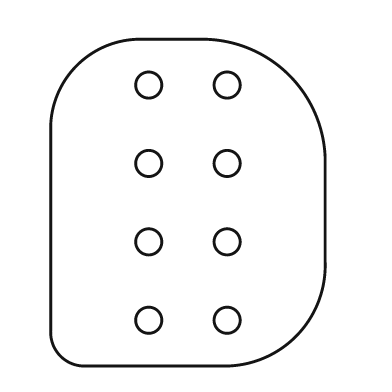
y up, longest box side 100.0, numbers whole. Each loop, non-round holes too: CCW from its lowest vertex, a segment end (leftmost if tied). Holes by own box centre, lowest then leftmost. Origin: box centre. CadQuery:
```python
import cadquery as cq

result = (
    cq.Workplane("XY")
    .moveTo(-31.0, -50.0)
    .lineTo(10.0, -50.0)
    .threePointArc((33.0, -41.0), (42.0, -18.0))
    .lineTo(42.0, 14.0)
    .threePointArc((31.0, 39.0), (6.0, 50.0))
    .lineTo(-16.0, 50.0)
    .threePointArc((-34.0, 42.0), (-42.0, 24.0))
    .lineTo(-42.0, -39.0)
    .threePointArc((-39.0, -47.0), (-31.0, -50.0))
    .close()
    .moveTo(-12.0, -36.0)
    .circle(4.0)
    .moveTo(12.0, -36.0)
    .circle(4.0)
    .moveTo(-12.0, -12.0)
    .circle(4.0)
    .moveTo(12.0, -12.0)
    .circle(4.0)
    .moveTo(-12.0, 12.0)
    .circle(4.0)
    .moveTo(12.0, 12.0)
    .circle(4.0)
    .moveTo(-12.0, 36.0)
    .circle(4.0)
    .moveTo(12.0, 36.0)
    .circle(4.0)
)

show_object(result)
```